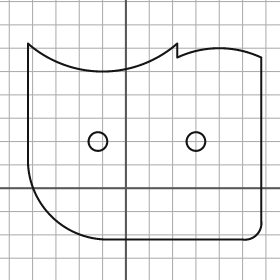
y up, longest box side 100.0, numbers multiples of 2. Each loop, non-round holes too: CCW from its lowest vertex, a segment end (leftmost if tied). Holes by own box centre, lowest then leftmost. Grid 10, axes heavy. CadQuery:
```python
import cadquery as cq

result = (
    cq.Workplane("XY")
    .moveTo(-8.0, -22.0)
    .lineTo(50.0, -22.0)
    .threePointArc((56.0, -20.0), (58.0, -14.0))
    .lineTo(58.0, 56.0)
    .threePointArc((40.0, 60.0), (22.0, 56.0))
    .lineTo(22.0, 62.0)
    .threePointArc((-10.0, 50.0), (-42.0, 62.0))
    .lineTo(-42.0, 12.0)
    .threePointArc((-32.0, -12.0), (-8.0, -22.0))
    .close()
    .moveTo(-12.0, 20.0)
    .circle(4.0)
    .moveTo(30.0, 20.0)
    .circle(4.0)
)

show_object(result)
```